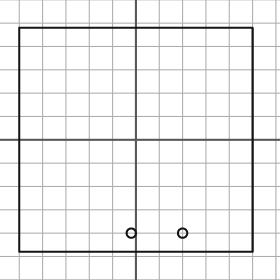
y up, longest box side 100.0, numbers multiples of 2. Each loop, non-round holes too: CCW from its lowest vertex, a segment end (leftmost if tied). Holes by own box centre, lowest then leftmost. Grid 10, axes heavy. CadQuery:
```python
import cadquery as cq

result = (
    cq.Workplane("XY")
    .moveTo(-50.0, -48.0)
    .lineTo(50.0, -48.0)
    .lineTo(50.0, 48.0)
    .lineTo(-50.0, 48.0)
    .close()
    .moveTo(-2.0, -40.0)
    .circle(2.0)
    .moveTo(20.0, -40.0)
    .circle(2.0)
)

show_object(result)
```